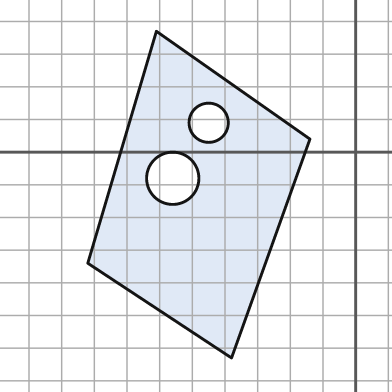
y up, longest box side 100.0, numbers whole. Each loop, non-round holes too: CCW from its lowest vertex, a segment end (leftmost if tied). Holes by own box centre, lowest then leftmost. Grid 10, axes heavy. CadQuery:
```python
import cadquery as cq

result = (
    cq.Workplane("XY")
    .moveTo(-38.0, -63.0)
    .lineTo(-14.0, 4.0)
    .lineTo(-61.0, 37.0)
    .lineTo(-82.0, -34.0)
    .close()
    .moveTo(-56.0, -8.0)
    .circle(8.0)
    .moveTo(-45.0, 9.0)
    .circle(6.0)
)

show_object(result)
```